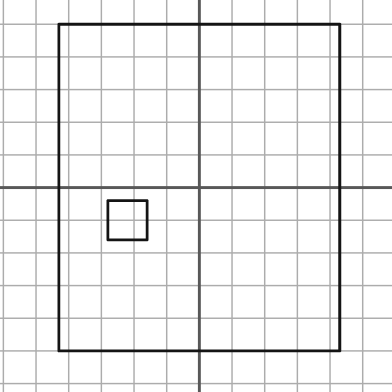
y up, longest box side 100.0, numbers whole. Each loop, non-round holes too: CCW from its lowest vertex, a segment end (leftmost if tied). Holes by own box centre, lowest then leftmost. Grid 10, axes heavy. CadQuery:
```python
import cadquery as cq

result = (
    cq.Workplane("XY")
    .moveTo(-43.0, -50.0)
    .lineTo(43.0, -50.0)
    .lineTo(43.0, 50.0)
    .lineTo(-43.0, 50.0)
    .close()
    .moveTo(-28.0, -16.0)
    .lineTo(-16.0, -16.0)
    .lineTo(-16.0, -4.0)
    .lineTo(-28.0, -4.0)
    .close()
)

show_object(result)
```